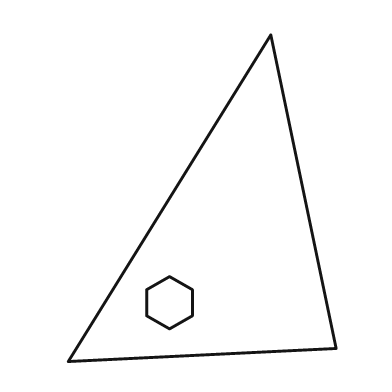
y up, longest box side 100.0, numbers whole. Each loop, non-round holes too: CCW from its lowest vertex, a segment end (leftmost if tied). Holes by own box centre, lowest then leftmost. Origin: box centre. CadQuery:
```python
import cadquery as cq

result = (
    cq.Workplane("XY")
    .moveTo(-41.0, -50.0)
    .lineTo(41.0, -46.0)
    .lineTo(21.0, 50.0)
    .close()
    .moveTo(-10.0, -40.0)
    .lineTo(-3.0, -36.0)
    .lineTo(-3.0, -28.0)
    .lineTo(-10.0, -24.0)
    .lineTo(-17.0, -28.0)
    .lineTo(-17.0, -36.0)
    .close()
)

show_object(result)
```